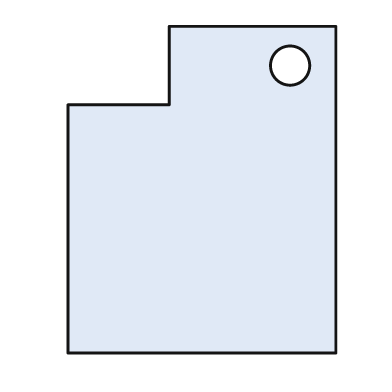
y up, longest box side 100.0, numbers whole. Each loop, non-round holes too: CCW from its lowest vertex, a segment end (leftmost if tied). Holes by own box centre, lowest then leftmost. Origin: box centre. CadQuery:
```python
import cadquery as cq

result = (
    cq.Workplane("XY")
    .moveTo(-41.0, -50.0)
    .lineTo(41.0, -50.0)
    .lineTo(41.0, 50.0)
    .lineTo(-10.0, 50.0)
    .lineTo(-10.0, 26.0)
    .lineTo(-41.0, 26.0)
    .close()
    .moveTo(27.0, 38.0)
    .circle(6.0)
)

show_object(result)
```